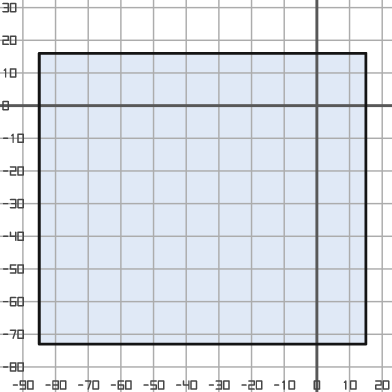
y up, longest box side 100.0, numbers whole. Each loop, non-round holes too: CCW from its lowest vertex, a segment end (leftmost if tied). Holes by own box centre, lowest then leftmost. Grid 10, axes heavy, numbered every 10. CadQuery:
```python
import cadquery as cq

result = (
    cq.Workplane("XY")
    .moveTo(-85.0, -73.0)
    .lineTo(15.0, -73.0)
    .lineTo(15.0, 16.0)
    .lineTo(-85.0, 16.0)
    .close()
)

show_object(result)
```